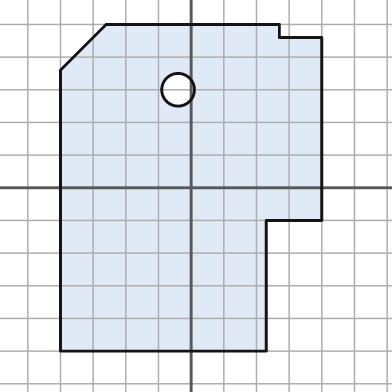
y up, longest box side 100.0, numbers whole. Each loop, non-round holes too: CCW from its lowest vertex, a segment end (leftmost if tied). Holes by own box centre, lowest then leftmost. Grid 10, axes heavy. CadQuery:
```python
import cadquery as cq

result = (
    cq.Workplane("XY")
    .moveTo(-40.0, -50.0)
    .lineTo(23.0, -50.0)
    .lineTo(23.0, -10.0)
    .lineTo(40.0, -10.0)
    .lineTo(40.0, 46.0)
    .lineTo(27.0, 46.0)
    .lineTo(27.0, 50.0)
    .lineTo(-26.0, 50.0)
    .lineTo(-40.0, 36.0)
    .close()
    .moveTo(-4.0, 30.0)
    .circle(5.0)
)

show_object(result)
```